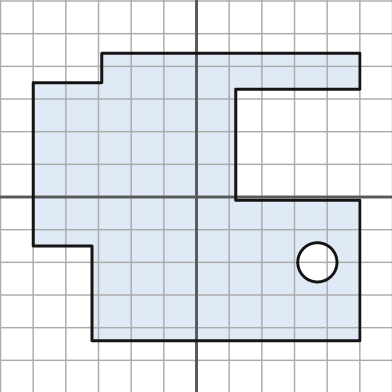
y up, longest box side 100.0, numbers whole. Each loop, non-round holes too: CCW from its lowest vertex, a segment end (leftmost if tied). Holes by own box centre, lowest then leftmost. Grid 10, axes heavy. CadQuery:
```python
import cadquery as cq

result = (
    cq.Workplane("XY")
    .moveTo(-32.0, -44.0)
    .lineTo(50.0, -44.0)
    .lineTo(50.0, -1.0)
    .lineTo(12.0, -1.0)
    .lineTo(12.0, 33.0)
    .lineTo(50.0, 33.0)
    .lineTo(50.0, 44.0)
    .lineTo(-29.0, 44.0)
    .lineTo(-29.0, 35.0)
    .lineTo(-50.0, 35.0)
    .lineTo(-50.0, -15.0)
    .lineTo(-32.0, -15.0)
    .close()
    .moveTo(37.0, -20.0)
    .circle(6.0)
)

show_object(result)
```